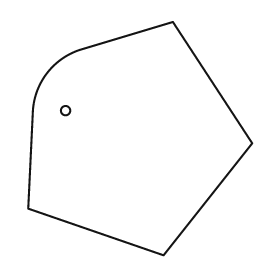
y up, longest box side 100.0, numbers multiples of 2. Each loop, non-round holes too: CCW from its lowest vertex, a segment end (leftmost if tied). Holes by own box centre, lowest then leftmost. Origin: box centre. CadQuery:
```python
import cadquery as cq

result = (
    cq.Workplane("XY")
    .moveTo(10.0, -50.0)
    .lineTo(48.0, -2.0)
    .lineTo(14.0, 50.0)
    .lineTo(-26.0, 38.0)
    .threePointArc((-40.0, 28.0), (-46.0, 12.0))
    .lineTo(-48.0, -30.0)
    .close()
    .moveTo(-32.0, 12.0)
    .circle(2.0)
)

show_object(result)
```